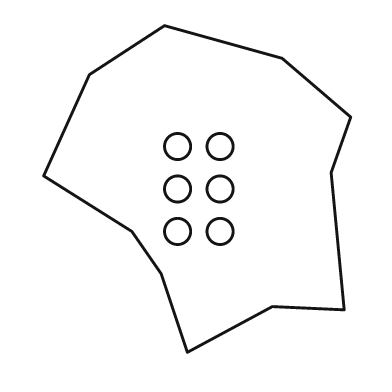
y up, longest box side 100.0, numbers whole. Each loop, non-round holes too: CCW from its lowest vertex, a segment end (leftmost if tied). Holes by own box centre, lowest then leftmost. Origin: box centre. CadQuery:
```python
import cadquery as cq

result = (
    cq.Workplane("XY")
    .moveTo(-3.0, -50.0)
    .lineTo(23.0, -36.0)
    .lineTo(45.0, -37.0)
    .lineTo(41.0, 5.0)
    .lineTo(47.0, 22.0)
    .lineTo(26.0, 40.0)
    .lineTo(-10.0, 50.0)
    .lineTo(-33.0, 35.0)
    .lineTo(-47.0, 4.0)
    .lineTo(-20.0, -13.0)
    .lineTo(-11.0, -26.0)
    .close()
    .moveTo(-6.0, -13.0)
    .circle(4.0)
    .moveTo(7.0, -13.0)
    .circle(4.0)
    .moveTo(-6.0, 0.0)
    .circle(4.0)
    .moveTo(7.0, 0.0)
    .circle(4.0)
    .moveTo(-6.0, 13.0)
    .circle(4.0)
    .moveTo(7.0, 13.0)
    .circle(4.0)
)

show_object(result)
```